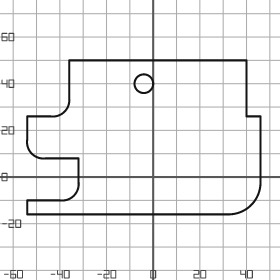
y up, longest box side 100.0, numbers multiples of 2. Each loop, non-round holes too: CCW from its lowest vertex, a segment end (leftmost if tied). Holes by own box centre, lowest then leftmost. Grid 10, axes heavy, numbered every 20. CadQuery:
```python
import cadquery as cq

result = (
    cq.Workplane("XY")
    .moveTo(-54.0, -16.0)
    .lineTo(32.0, -16.0)
    .threePointArc((42.0, -12.0), (46.0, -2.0))
    .lineTo(46.0, 26.0)
    .lineTo(40.0, 26.0)
    .lineTo(40.0, 50.0)
    .lineTo(-36.0, 50.0)
    .lineTo(-36.0, 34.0)
    .threePointArc((-38.0, 28.0), (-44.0, 26.0))
    .lineTo(-54.0, 26.0)
    .lineTo(-54.0, 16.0)
    .threePointArc((-52.0, 10.0), (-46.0, 8.0))
    .lineTo(-32.0, 8.0)
    .lineTo(-32.0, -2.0)
    .threePointArc((-34.0, -8.0), (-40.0, -10.0))
    .lineTo(-54.0, -10.0)
    .close()
    .moveTo(-4.0, 40.0)
    .circle(4.0)
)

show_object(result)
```